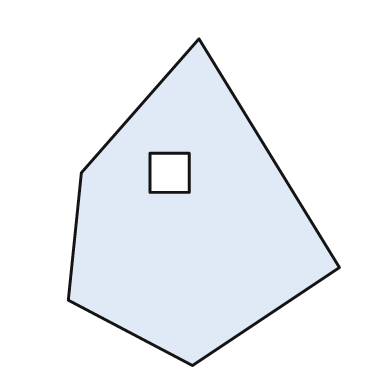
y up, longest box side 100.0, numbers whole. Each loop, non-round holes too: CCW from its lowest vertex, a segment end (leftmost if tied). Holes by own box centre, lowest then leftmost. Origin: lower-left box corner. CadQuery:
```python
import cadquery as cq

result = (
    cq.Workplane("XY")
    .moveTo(38.0, 0.0)
    .lineTo(83.0, 30.0)
    .lineTo(40.0, 100.0)
    .lineTo(4.0, 59.0)
    .lineTo(0.0, 20.0)
    .close()
    .moveTo(25.0, 53.0)
    .lineTo(37.0, 53.0)
    .lineTo(37.0, 65.0)
    .lineTo(25.0, 65.0)
    .close()
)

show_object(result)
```